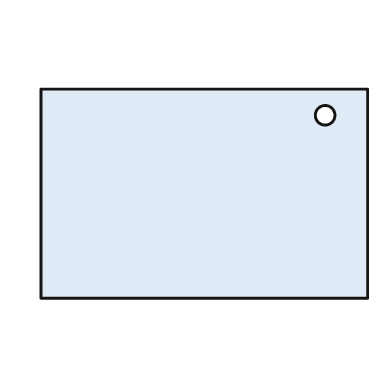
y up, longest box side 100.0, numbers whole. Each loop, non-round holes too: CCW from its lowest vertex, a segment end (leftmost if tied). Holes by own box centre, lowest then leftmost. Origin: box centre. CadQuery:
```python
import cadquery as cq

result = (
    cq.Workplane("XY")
    .moveTo(-50.0, -32.0)
    .lineTo(50.0, -32.0)
    .lineTo(50.0, 32.0)
    .lineTo(-50.0, 32.0)
    .close()
    .moveTo(37.0, 24.0)
    .circle(3.0)
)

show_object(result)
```